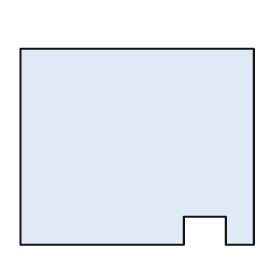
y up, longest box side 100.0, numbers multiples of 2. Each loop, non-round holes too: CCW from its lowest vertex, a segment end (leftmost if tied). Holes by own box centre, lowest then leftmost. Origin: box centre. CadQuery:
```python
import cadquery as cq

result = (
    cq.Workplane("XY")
    .moveTo(-50.0, -42.0)
    .lineTo(20.0, -42.0)
    .lineTo(20.0, -30.0)
    .lineTo(38.0, -30.0)
    .lineTo(38.0, -42.0)
    .lineTo(50.0, -42.0)
    .lineTo(50.0, 42.0)
    .lineTo(-50.0, 42.0)
    .close()
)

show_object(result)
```